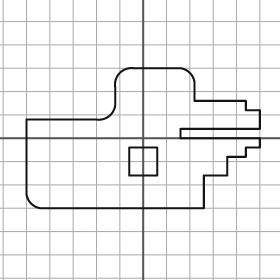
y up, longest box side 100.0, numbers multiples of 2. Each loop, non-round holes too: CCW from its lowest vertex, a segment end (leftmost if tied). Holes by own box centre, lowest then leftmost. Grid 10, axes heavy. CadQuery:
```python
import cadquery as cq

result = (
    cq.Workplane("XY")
    .moveTo(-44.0, -30.0)
    .lineTo(26.0, -30.0)
    .lineTo(26.0, -16.0)
    .lineTo(36.0, -16.0)
    .lineTo(36.0, -8.0)
    .lineTo(44.0, -8.0)
    .lineTo(44.0, -4.0)
    .lineTo(50.0, -4.0)
    .lineTo(50.0, 0.0)
    .lineTo(16.0, 0.0)
    .lineTo(16.0, 4.0)
    .lineTo(50.0, 4.0)
    .lineTo(50.0, 12.0)
    .lineTo(44.0, 12.0)
    .lineTo(44.0, 16.0)
    .lineTo(22.0, 16.0)
    .lineTo(22.0, 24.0)
    .threePointArc((20.0, 28.0), (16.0, 30.0))
    .lineTo(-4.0, 30.0)
    .threePointArc((-10.0, 28.0), (-12.0, 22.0))
    .lineTo(-12.0, 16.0)
    .threePointArc((-14.0, 10.0), (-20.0, 8.0))
    .lineTo(-50.0, 8.0)
    .lineTo(-50.0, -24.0)
    .threePointArc((-48.0, -28.0), (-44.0, -30.0))
    .close()
    .moveTo(-6.0, -16.0)
    .lineTo(6.0, -16.0)
    .lineTo(6.0, -4.0)
    .lineTo(-6.0, -4.0)
    .close()
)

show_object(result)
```